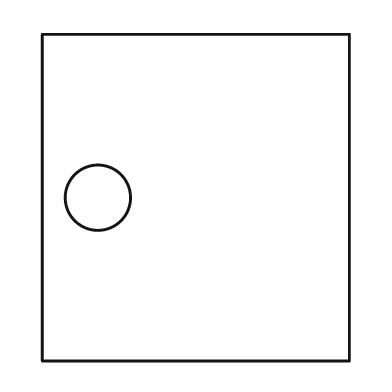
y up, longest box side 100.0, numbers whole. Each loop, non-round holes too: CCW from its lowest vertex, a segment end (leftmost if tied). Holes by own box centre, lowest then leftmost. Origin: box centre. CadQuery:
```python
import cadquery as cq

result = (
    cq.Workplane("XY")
    .moveTo(-47.0, -50.0)
    .lineTo(47.0, -50.0)
    .lineTo(47.0, 50.0)
    .lineTo(-47.0, 50.0)
    .close()
    .moveTo(-30.0, 0.0)
    .circle(10.0)
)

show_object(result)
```